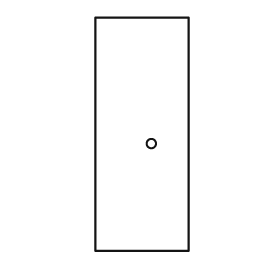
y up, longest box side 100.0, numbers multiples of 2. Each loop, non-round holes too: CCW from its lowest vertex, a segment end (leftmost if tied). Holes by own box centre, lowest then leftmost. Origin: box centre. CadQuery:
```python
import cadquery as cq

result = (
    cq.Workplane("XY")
    .moveTo(-20.0, -50.0)
    .lineTo(20.0, -50.0)
    .lineTo(20.0, 50.0)
    .lineTo(-20.0, 50.0)
    .close()
    .moveTo(4.0, -4.0)
    .circle(2.0)
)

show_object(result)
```